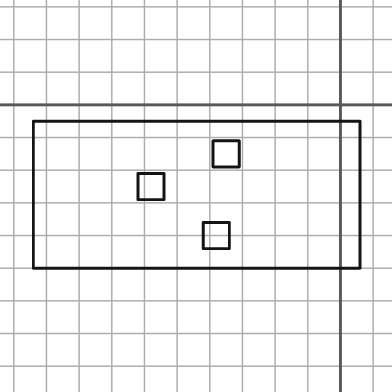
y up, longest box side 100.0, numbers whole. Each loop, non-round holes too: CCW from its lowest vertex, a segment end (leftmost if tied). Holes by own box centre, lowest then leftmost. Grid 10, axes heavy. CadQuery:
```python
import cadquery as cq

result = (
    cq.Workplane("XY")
    .moveTo(-94.0, -50.0)
    .lineTo(6.0, -50.0)
    .lineTo(6.0, -5.0)
    .lineTo(-94.0, -5.0)
    .close()
    .moveTo(-42.0, -44.0)
    .lineTo(-34.0, -44.0)
    .lineTo(-34.0, -36.0)
    .lineTo(-42.0, -36.0)
    .close()
    .moveTo(-62.0, -29.0)
    .lineTo(-54.0, -29.0)
    .lineTo(-54.0, -21.0)
    .lineTo(-62.0, -21.0)
    .close()
    .moveTo(-39.0, -19.0)
    .lineTo(-31.0, -19.0)
    .lineTo(-31.0, -11.0)
    .lineTo(-39.0, -11.0)
    .close()
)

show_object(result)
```